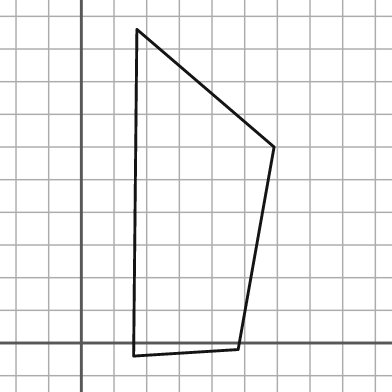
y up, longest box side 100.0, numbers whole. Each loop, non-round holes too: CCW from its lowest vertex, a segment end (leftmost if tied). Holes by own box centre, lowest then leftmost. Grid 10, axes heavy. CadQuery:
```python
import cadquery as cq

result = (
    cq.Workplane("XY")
    .moveTo(16.0, -4.0)
    .lineTo(48.0, -2.0)
    .lineTo(59.0, 60.0)
    .lineTo(17.0, 96.0)
    .close()
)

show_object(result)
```